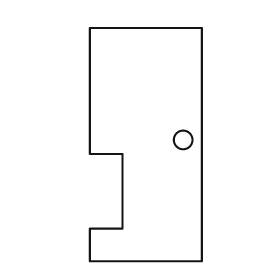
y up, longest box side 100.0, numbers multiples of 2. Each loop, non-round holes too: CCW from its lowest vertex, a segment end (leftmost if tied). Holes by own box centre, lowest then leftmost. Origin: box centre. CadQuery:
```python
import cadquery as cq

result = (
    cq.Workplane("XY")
    .moveTo(-24.0, -50.0)
    .lineTo(24.0, -50.0)
    .lineTo(24.0, 50.0)
    .lineTo(-24.0, 50.0)
    .lineTo(-24.0, -4.0)
    .lineTo(-10.0, -4.0)
    .lineTo(-10.0, -36.0)
    .lineTo(-24.0, -36.0)
    .close()
    .moveTo(16.0, 2.0)
    .circle(4.0)
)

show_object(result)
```